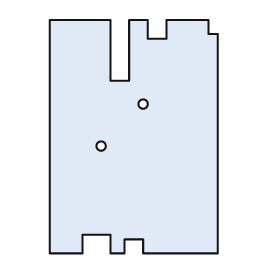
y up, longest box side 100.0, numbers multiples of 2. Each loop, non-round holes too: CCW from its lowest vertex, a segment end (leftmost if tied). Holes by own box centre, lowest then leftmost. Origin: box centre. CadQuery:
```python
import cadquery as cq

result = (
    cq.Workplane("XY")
    .moveTo(-36.0, -50.0)
    .lineTo(-22.0, -50.0)
    .lineTo(-22.0, -42.0)
    .lineTo(-10.0, -42.0)
    .lineTo(-10.0, -50.0)
    .lineTo(-4.0, -50.0)
    .lineTo(-4.0, -44.0)
    .lineTo(4.0, -44.0)
    .lineTo(4.0, -50.0)
    .lineTo(36.0, -50.0)
    .lineTo(36.0, 44.0)
    .lineTo(32.0, 44.0)
    .lineTo(32.0, 50.0)
    .lineTo(14.0, 50.0)
    .lineTo(14.0, 42.0)
    .lineTo(6.0, 42.0)
    .lineTo(6.0, 50.0)
    .lineTo(-2.0, 50.0)
    .lineTo(-2.0, 24.0)
    .lineTo(-10.0, 24.0)
    .lineTo(-10.0, 50.0)
    .lineTo(-36.0, 50.0)
    .close()
    .moveTo(-14.0, -4.0)
    .circle(2.0)
    .moveTo(4.0, 14.0)
    .circle(2.0)
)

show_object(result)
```